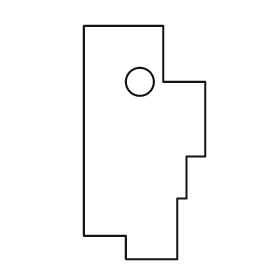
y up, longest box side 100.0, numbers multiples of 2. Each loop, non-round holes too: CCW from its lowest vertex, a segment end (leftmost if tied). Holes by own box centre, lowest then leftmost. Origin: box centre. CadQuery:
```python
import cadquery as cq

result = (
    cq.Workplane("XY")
    .moveTo(-8.0, -50.0)
    .lineTo(14.0, -50.0)
    .lineTo(14.0, -24.0)
    .lineTo(18.0, -24.0)
    .lineTo(18.0, -6.0)
    .lineTo(26.0, -6.0)
    .lineTo(26.0, 26.0)
    .lineTo(8.0, 26.0)
    .lineTo(8.0, 50.0)
    .lineTo(-26.0, 50.0)
    .lineTo(-26.0, -40.0)
    .lineTo(-8.0, -40.0)
    .close()
    .moveTo(-2.0, 26.0)
    .circle(6.0)
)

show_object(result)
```